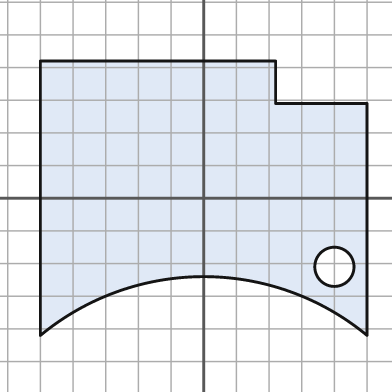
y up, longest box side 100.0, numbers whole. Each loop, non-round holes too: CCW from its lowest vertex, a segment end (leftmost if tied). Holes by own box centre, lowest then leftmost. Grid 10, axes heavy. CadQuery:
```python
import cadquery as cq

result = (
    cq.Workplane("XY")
    .moveTo(-50.0, -42.0)
    .threePointArc((0.0, -24.0), (50.0, -42.0))
    .lineTo(50.0, 29.0)
    .lineTo(22.0, 29.0)
    .lineTo(22.0, 42.0)
    .lineTo(-50.0, 42.0)
    .close()
    .moveTo(40.0, -21.0)
    .circle(6.0)
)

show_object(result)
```